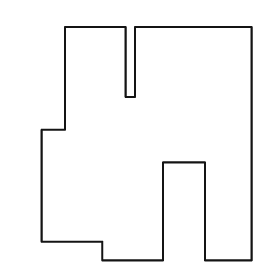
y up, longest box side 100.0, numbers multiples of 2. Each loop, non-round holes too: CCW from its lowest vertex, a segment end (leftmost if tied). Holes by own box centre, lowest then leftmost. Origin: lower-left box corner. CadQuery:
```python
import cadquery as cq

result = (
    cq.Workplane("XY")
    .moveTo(26.0, 0.0)
    .lineTo(52.0, 0.0)
    .lineTo(52.0, 42.0)
    .lineTo(70.0, 42.0)
    .lineTo(70.0, 0.0)
    .lineTo(90.0, 0.0)
    .lineTo(90.0, 100.0)
    .lineTo(40.0, 100.0)
    .lineTo(40.0, 70.0)
    .lineTo(36.0, 70.0)
    .lineTo(36.0, 100.0)
    .lineTo(10.0, 100.0)
    .lineTo(10.0, 56.0)
    .lineTo(0.0, 56.0)
    .lineTo(0.0, 8.0)
    .lineTo(26.0, 8.0)
    .close()
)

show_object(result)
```